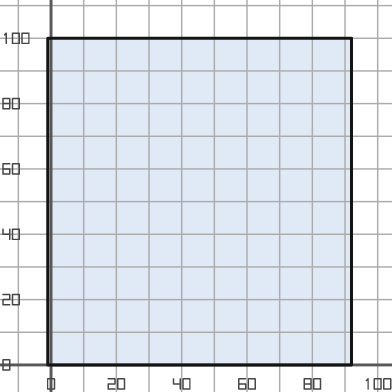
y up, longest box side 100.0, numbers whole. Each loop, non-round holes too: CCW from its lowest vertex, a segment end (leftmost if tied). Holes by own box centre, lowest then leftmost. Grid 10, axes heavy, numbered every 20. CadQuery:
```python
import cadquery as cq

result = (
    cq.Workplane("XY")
    .moveTo(-1.0, 0.0)
    .lineTo(92.0, 0.0)
    .lineTo(92.0, 100.0)
    .lineTo(-1.0, 100.0)
    .close()
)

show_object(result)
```